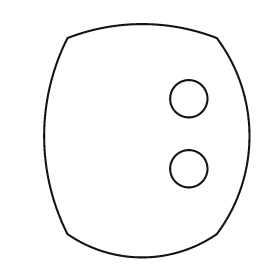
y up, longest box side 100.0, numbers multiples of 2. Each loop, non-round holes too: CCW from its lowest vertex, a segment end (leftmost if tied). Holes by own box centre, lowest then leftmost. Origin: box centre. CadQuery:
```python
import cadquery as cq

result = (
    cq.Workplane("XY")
    .moveTo(-34.0, -40.0)
    .threePointArc((-2.0, -50.0), (30.0, -40.0))
    .threePointArc((44.0, 2.0), (30.0, 44.0))
    .threePointArc((-2.0, 50.0), (-34.0, 44.0))
    .threePointArc((-44.0, 2.0), (-34.0, -40.0))
    .close()
    .moveTo(18.0, -12.0)
    .circle(8.0)
    .moveTo(18.0, 18.0)
    .circle(8.0)
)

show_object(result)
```